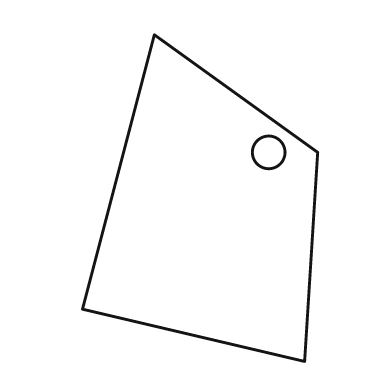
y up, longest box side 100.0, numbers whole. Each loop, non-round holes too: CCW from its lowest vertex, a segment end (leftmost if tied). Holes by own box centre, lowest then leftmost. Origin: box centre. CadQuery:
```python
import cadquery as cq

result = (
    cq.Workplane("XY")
    .moveTo(32.0, -50.0)
    .lineTo(36.0, 14.0)
    .lineTo(-14.0, 50.0)
    .lineTo(-36.0, -34.0)
    .close()
    .moveTo(21.0, 14.0)
    .circle(5.0)
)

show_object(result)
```